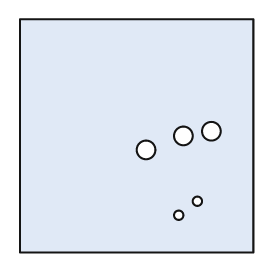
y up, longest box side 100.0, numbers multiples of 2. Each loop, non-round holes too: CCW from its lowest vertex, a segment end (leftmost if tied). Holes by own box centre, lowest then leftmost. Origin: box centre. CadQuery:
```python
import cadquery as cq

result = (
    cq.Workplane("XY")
    .moveTo(-50.0, -50.0)
    .lineTo(50.0, -50.0)
    .lineTo(50.0, 50.0)
    .lineTo(-50.0, 50.0)
    .close()
    .moveTo(18.0, -34.0)
    .circle(2.0)
    .moveTo(26.0, -28.0)
    .circle(2.0)
    .moveTo(4.0, -6.0)
    .circle(4.0)
    .moveTo(20.0, 0.0)
    .circle(4.0)
    .moveTo(32.0, 2.0)
    .circle(4.0)
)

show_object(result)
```